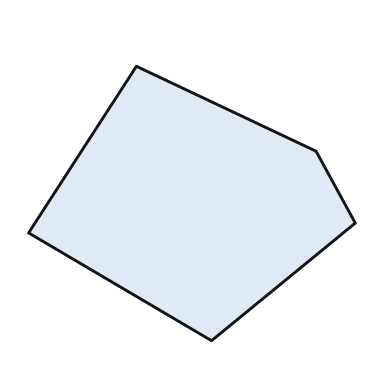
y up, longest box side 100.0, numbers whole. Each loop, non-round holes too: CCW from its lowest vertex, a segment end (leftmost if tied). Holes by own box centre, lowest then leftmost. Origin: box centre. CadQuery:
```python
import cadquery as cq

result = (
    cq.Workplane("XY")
    .moveTo(6.0, -42.0)
    .lineTo(50.0, -6.0)
    .lineTo(38.0, 16.0)
    .lineTo(-17.0, 42.0)
    .lineTo(-50.0, -9.0)
    .close()
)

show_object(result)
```